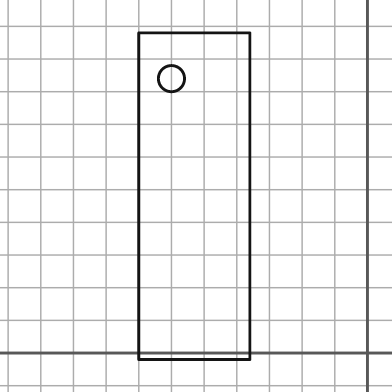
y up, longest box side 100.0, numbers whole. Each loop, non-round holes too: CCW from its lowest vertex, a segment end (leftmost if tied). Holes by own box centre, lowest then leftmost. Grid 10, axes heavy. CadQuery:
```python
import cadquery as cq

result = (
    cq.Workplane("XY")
    .moveTo(-70.0, -2.0)
    .lineTo(-36.0, -2.0)
    .lineTo(-36.0, 98.0)
    .lineTo(-70.0, 98.0)
    .close()
    .moveTo(-60.0, 84.0)
    .circle(4.0)
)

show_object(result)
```